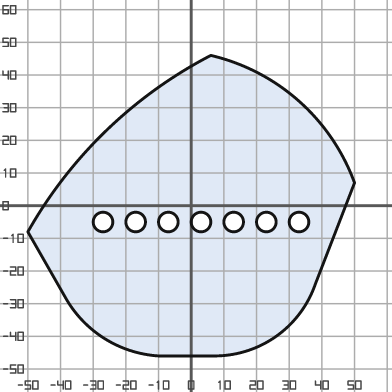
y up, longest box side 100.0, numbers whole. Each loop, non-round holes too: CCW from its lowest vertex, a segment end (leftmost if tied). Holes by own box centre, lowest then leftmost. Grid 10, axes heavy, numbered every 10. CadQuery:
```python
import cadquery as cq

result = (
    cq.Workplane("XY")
    .moveTo(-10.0, -46.0)
    .lineTo(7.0, -46.0)
    .threePointArc((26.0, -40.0), (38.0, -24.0))
    .lineTo(50.0, 7.0)
    .threePointArc((33.0, 32.0), (6.0, 46.0))
    .threePointArc((-26.0, 23.0), (-50.0, -8.0))
    .lineTo(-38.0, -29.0)
    .threePointArc((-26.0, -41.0), (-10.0, -46.0))
    .close()
    .moveTo(-27.0, -5.0)
    .circle(3.0)
    .moveTo(-17.0, -5.0)
    .circle(3.0)
    .moveTo(-7.0, -5.0)
    .circle(3.0)
    .moveTo(3.0, -5.0)
    .circle(3.0)
    .moveTo(13.0, -5.0)
    .circle(3.0)
    .moveTo(23.0, -5.0)
    .circle(3.0)
    .moveTo(33.0, -5.0)
    .circle(3.0)
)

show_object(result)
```